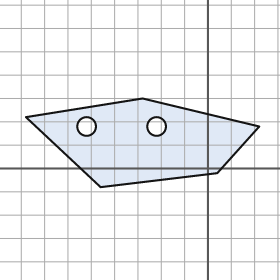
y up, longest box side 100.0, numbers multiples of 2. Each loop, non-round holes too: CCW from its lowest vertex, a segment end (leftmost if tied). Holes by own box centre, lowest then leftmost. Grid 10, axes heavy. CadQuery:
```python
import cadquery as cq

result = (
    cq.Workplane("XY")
    .moveTo(-46.0, -8.0)
    .lineTo(4.0, -2.0)
    .lineTo(22.0, 18.0)
    .lineTo(-28.0, 30.0)
    .lineTo(-78.0, 22.0)
    .close()
    .moveTo(-52.0, 18.0)
    .circle(4.0)
    .moveTo(-22.0, 18.0)
    .circle(4.0)
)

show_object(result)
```